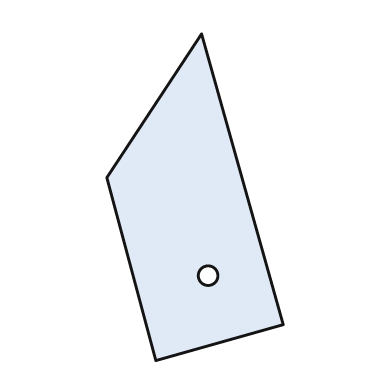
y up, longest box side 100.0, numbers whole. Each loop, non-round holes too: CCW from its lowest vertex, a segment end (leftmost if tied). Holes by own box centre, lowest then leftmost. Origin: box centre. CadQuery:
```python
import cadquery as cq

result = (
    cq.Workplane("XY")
    .moveTo(-12.0, -50.0)
    .lineTo(27.0, -39.0)
    .lineTo(2.0, 50.0)
    .lineTo(-27.0, 6.0)
    .close()
    .moveTo(4.0, -24.0)
    .circle(3.0)
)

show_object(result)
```